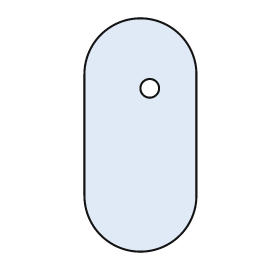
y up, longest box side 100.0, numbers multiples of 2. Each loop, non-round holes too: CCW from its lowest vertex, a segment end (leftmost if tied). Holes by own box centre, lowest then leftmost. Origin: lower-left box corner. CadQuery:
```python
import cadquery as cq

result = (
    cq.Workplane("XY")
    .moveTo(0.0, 24.0)
    .threePointArc((24.0, 0.0), (48.0, 24.0))
    .lineTo(48.0, 76.0)
    .threePointArc((24.0, 100.0), (0.0, 76.0))
    .close()
    .moveTo(28.0, 70.0)
    .circle(4.0)
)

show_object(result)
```